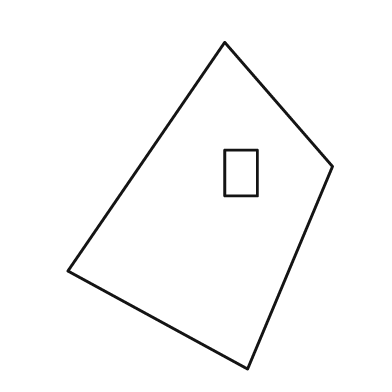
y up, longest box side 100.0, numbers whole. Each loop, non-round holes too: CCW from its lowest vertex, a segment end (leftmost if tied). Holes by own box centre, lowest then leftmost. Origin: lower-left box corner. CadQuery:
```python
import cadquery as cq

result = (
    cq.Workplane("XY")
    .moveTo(55.0, 0.0)
    .lineTo(81.0, 62.0)
    .lineTo(48.0, 100.0)
    .lineTo(0.0, 30.0)
    .close()
    .moveTo(48.0, 53.0)
    .lineTo(58.0, 53.0)
    .lineTo(58.0, 67.0)
    .lineTo(48.0, 67.0)
    .close()
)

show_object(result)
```